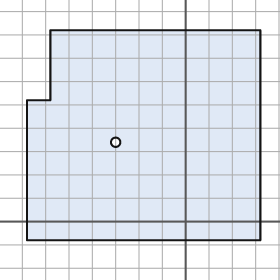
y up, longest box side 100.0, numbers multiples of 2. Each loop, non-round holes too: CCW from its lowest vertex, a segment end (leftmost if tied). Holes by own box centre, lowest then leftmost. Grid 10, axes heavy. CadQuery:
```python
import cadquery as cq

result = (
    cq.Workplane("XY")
    .moveTo(-68.0, -8.0)
    .lineTo(32.0, -8.0)
    .lineTo(32.0, 82.0)
    .lineTo(-58.0, 82.0)
    .lineTo(-58.0, 52.0)
    .lineTo(-68.0, 52.0)
    .close()
    .moveTo(-30.0, 34.0)
    .circle(2.0)
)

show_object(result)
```